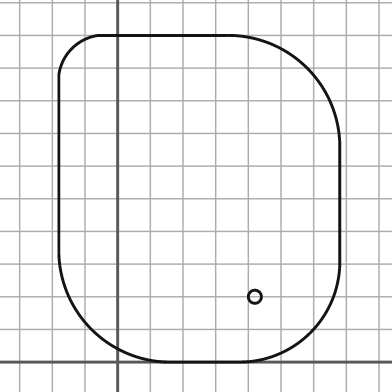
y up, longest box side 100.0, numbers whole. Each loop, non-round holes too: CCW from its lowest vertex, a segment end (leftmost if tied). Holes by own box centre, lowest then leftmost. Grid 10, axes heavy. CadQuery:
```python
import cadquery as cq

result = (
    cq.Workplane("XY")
    .moveTo(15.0, 0.0)
    .lineTo(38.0, 0.0)
    .threePointArc((59.0, 9.0), (68.0, 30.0))
    .lineTo(68.0, 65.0)
    .threePointArc((58.0, 90.0), (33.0, 100.0))
    .lineTo(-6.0, 100.0)
    .threePointArc((-14.0, 96.0), (-18.0, 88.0))
    .lineTo(-18.0, 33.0)
    .threePointArc((-8.0, 10.0), (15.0, 0.0))
    .close()
    .moveTo(42.0, 20.0)
    .circle(2.0)
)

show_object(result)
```